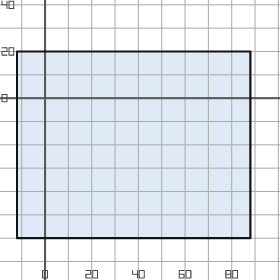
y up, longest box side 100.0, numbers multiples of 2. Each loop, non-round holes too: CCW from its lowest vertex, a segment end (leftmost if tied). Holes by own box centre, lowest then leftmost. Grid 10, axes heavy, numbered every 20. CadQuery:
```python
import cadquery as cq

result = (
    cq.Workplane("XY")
    .moveTo(-12.0, -60.0)
    .lineTo(88.0, -60.0)
    .lineTo(88.0, 20.0)
    .lineTo(-12.0, 20.0)
    .close()
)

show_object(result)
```